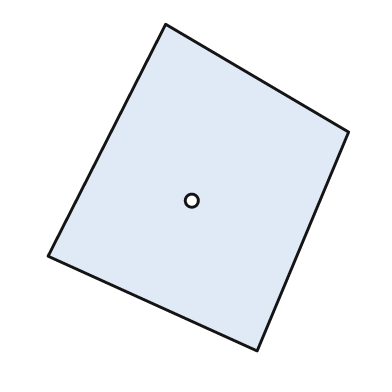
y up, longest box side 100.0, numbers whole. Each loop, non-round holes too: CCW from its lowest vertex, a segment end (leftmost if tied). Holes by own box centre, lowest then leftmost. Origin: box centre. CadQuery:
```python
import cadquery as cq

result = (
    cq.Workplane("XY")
    .moveTo(18.0, -50.0)
    .lineTo(46.0, 17.0)
    .lineTo(-10.0, 50.0)
    .lineTo(-46.0, -21.0)
    .close()
    .moveTo(-2.0, -4.0)
    .circle(2.0)
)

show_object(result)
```